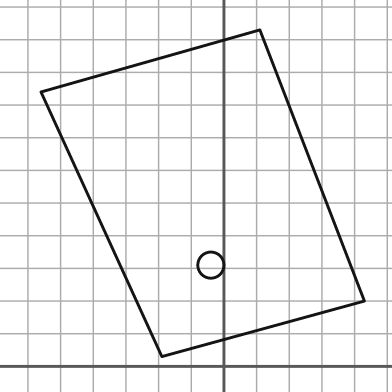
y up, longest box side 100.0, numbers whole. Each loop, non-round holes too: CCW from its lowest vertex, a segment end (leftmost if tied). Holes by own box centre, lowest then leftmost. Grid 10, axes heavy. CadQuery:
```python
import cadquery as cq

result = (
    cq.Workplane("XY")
    .moveTo(-19.0, 3.0)
    .lineTo(43.0, 20.0)
    .lineTo(11.0, 103.0)
    .lineTo(-56.0, 84.0)
    .close()
    .moveTo(-4.0, 31.0)
    .circle(4.0)
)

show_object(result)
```